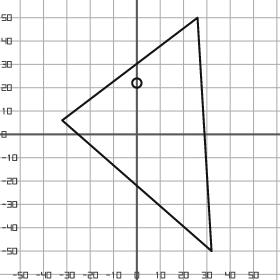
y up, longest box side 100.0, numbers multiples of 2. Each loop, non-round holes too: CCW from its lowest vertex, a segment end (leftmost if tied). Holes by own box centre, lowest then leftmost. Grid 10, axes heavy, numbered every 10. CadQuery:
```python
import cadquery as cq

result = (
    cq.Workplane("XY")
    .moveTo(32.0, -50.0)
    .lineTo(26.0, 50.0)
    .lineTo(-32.0, 6.0)
    .close()
    .moveTo(0.0, 22.0)
    .circle(2.0)
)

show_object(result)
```